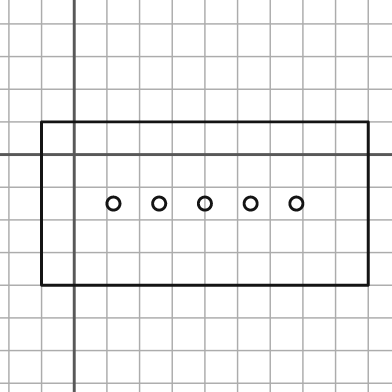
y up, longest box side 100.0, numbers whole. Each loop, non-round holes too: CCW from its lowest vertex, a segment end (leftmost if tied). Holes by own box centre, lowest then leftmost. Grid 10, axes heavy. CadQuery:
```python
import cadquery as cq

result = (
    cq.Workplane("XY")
    .moveTo(-10.0, -40.0)
    .lineTo(90.0, -40.0)
    .lineTo(90.0, 10.0)
    .lineTo(-10.0, 10.0)
    .close()
    .moveTo(12.0, -15.0)
    .circle(2.0)
    .moveTo(26.0, -15.0)
    .circle(2.0)
    .moveTo(40.0, -15.0)
    .circle(2.0)
    .moveTo(54.0, -15.0)
    .circle(2.0)
    .moveTo(68.0, -15.0)
    .circle(2.0)
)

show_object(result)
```